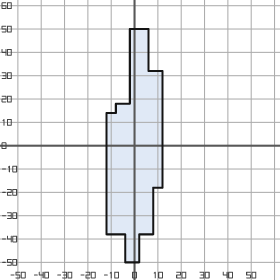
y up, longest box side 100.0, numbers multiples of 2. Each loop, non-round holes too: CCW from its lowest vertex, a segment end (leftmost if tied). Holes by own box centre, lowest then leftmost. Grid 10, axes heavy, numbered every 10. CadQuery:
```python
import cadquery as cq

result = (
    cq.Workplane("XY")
    .moveTo(-4.0, -50.0)
    .lineTo(2.0, -50.0)
    .lineTo(2.0, -38.0)
    .lineTo(8.0, -38.0)
    .lineTo(8.0, -18.0)
    .lineTo(12.0, -18.0)
    .lineTo(12.0, 32.0)
    .lineTo(6.0, 32.0)
    .lineTo(6.0, 50.0)
    .lineTo(-2.0, 50.0)
    .lineTo(-2.0, 18.0)
    .lineTo(-8.0, 18.0)
    .lineTo(-8.0, 14.0)
    .lineTo(-12.0, 14.0)
    .lineTo(-12.0, -38.0)
    .lineTo(-4.0, -38.0)
    .close()
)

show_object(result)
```